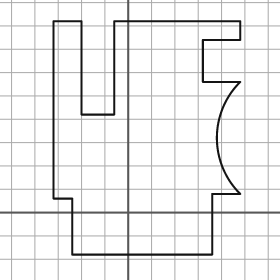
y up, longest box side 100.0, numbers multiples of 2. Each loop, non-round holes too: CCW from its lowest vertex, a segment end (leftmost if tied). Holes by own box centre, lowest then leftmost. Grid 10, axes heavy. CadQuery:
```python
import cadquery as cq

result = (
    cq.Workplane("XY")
    .moveTo(-24.0, -18.0)
    .lineTo(36.0, -18.0)
    .lineTo(36.0, 8.0)
    .lineTo(48.0, 8.0)
    .threePointArc((38.0, 32.0), (48.0, 56.0))
    .lineTo(32.0, 56.0)
    .lineTo(32.0, 74.0)
    .lineTo(48.0, 74.0)
    .lineTo(48.0, 82.0)
    .lineTo(-6.0, 82.0)
    .lineTo(-6.0, 42.0)
    .lineTo(-20.0, 42.0)
    .lineTo(-20.0, 82.0)
    .lineTo(-32.0, 82.0)
    .lineTo(-32.0, 6.0)
    .lineTo(-24.0, 6.0)
    .close()
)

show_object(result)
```